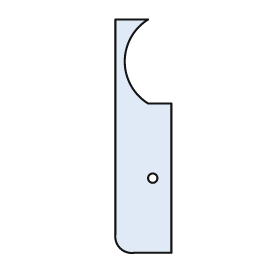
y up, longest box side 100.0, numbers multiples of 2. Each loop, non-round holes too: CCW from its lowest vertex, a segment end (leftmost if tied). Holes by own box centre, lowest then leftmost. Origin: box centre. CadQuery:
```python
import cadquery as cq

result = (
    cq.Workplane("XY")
    .moveTo(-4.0, -50.0)
    .lineTo(12.0, -50.0)
    .lineTo(12.0, 14.0)
    .lineTo(2.0, 14.0)
    .threePointArc((-8.0, 32.0), (2.0, 50.0))
    .lineTo(-12.0, 50.0)
    .lineTo(-12.0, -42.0)
    .threePointArc((-10.0, -48.0), (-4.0, -50.0))
    .close()
    .moveTo(4.0, -18.0)
    .circle(2.0)
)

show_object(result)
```